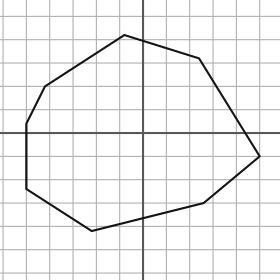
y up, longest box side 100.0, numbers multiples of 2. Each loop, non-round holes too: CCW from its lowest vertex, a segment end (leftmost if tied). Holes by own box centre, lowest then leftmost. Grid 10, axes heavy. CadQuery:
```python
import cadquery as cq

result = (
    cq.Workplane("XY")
    .moveTo(-22.0, -42.0)
    .lineTo(26.0, -30.0)
    .lineTo(50.0, -10.0)
    .lineTo(24.0, 32.0)
    .lineTo(-8.0, 42.0)
    .lineTo(-42.0, 20.0)
    .lineTo(-50.0, 4.0)
    .lineTo(-50.0, -24.0)
    .close()
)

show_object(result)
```